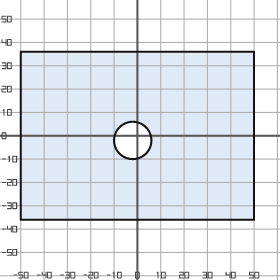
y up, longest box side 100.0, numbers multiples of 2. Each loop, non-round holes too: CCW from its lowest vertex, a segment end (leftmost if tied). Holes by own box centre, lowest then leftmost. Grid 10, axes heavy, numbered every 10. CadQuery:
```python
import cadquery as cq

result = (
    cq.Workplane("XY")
    .moveTo(-50.0, -36.0)
    .lineTo(50.0, -36.0)
    .lineTo(50.0, 36.0)
    .lineTo(-50.0, 36.0)
    .close()
    .moveTo(-2.0, -2.0)
    .circle(8.0)
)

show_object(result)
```